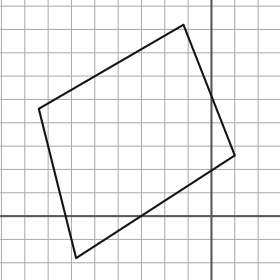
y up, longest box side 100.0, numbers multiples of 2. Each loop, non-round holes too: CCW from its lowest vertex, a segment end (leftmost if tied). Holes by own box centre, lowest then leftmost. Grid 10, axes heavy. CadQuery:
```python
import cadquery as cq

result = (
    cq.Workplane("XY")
    .moveTo(-58.0, -18.0)
    .lineTo(10.0, 26.0)
    .lineTo(-12.0, 82.0)
    .lineTo(-74.0, 46.0)
    .close()
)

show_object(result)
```